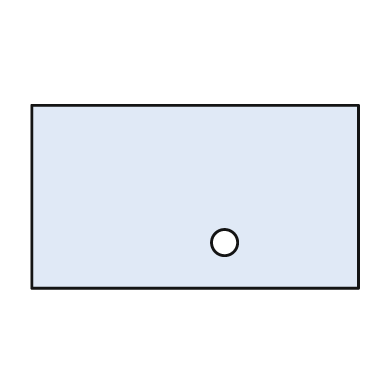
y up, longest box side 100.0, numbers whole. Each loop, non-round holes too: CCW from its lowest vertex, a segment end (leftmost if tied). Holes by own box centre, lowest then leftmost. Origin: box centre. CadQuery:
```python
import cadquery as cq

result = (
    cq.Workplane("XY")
    .moveTo(-50.0, -28.0)
    .lineTo(50.0, -28.0)
    .lineTo(50.0, 28.0)
    .lineTo(-50.0, 28.0)
    .close()
    .moveTo(9.0, -14.0)
    .circle(4.0)
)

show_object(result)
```